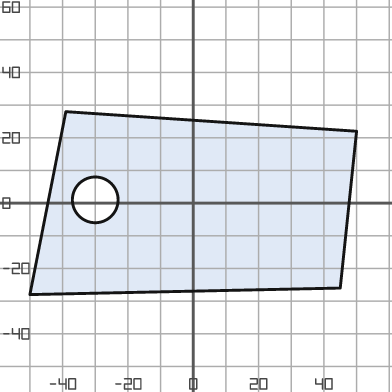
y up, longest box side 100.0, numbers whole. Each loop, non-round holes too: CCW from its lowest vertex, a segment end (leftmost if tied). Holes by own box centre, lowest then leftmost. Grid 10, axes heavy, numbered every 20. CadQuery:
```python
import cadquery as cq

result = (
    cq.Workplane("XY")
    .moveTo(-50.0, -28.0)
    .lineTo(45.0, -26.0)
    .lineTo(50.0, 22.0)
    .lineTo(-39.0, 28.0)
    .close()
    .moveTo(-30.0, 1.0)
    .circle(7.0)
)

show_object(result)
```